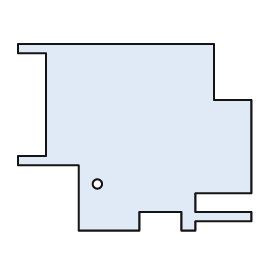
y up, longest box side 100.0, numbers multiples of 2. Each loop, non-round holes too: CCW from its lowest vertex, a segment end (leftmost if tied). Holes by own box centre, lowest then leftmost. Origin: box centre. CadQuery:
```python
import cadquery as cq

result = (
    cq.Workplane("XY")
    .moveTo(-24.0, -40.0)
    .lineTo(2.0, -40.0)
    .lineTo(2.0, -32.0)
    .lineTo(20.0, -32.0)
    .lineTo(20.0, -40.0)
    .lineTo(26.0, -40.0)
    .lineTo(26.0, -36.0)
    .lineTo(50.0, -36.0)
    .lineTo(50.0, -32.0)
    .lineTo(26.0, -32.0)
    .lineTo(26.0, -24.0)
    .lineTo(50.0, -24.0)
    .lineTo(50.0, 16.0)
    .lineTo(34.0, 16.0)
    .lineTo(34.0, 40.0)
    .lineTo(-50.0, 40.0)
    .lineTo(-50.0, 36.0)
    .lineTo(-38.0, 36.0)
    .lineTo(-38.0, -8.0)
    .lineTo(-50.0, -8.0)
    .lineTo(-50.0, -12.0)
    .lineTo(-24.0, -12.0)
    .close()
    .moveTo(-16.0, -20.0)
    .circle(2.0)
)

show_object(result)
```